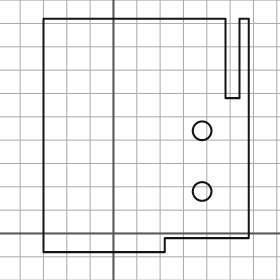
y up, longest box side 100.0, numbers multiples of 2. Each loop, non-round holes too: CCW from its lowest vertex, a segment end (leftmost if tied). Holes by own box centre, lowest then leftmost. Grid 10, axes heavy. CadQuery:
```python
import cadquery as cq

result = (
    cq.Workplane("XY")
    .moveTo(-30.0, -8.0)
    .lineTo(22.0, -8.0)
    .lineTo(22.0, -2.0)
    .lineTo(58.0, -2.0)
    .lineTo(58.0, 92.0)
    .lineTo(54.0, 92.0)
    .lineTo(54.0, 58.0)
    .lineTo(48.0, 58.0)
    .lineTo(48.0, 92.0)
    .lineTo(-30.0, 92.0)
    .close()
    .moveTo(38.0, 18.0)
    .circle(4.0)
    .moveTo(38.0, 44.0)
    .circle(4.0)
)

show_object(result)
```